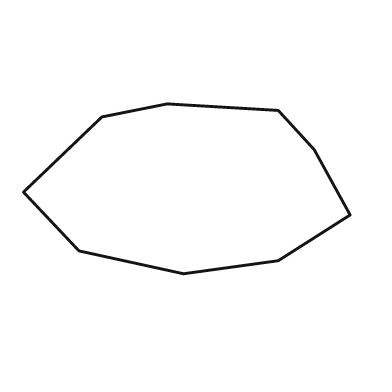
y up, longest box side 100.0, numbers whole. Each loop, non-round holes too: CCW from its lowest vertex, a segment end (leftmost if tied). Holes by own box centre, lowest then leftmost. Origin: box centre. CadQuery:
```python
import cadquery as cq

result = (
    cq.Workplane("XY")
    .moveTo(-1.0, -26.0)
    .lineTo(28.0, -22.0)
    .lineTo(50.0, -8.0)
    .lineTo(39.0, 12.0)
    .lineTo(28.0, 24.0)
    .lineTo(-6.0, 26.0)
    .lineTo(-26.0, 22.0)
    .lineTo(-50.0, -1.0)
    .lineTo(-33.0, -19.0)
    .close()
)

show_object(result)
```